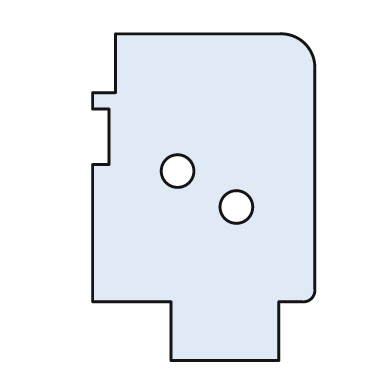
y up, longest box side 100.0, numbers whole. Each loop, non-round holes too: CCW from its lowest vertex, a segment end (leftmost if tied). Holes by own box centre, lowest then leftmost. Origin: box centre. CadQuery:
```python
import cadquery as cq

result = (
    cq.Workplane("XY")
    .moveTo(-10.0, -50.0)
    .lineTo(23.0, -50.0)
    .lineTo(23.0, -32.0)
    .lineTo(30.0, -32.0)
    .threePointArc((33.0, -31.0), (34.0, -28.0))
    .lineTo(34.0, 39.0)
    .threePointArc((31.0, 47.0), (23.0, 50.0))
    .lineTo(-27.0, 50.0)
    .lineTo(-27.0, 32.0)
    .lineTo(-34.0, 32.0)
    .lineTo(-34.0, 27.0)
    .lineTo(-29.0, 27.0)
    .lineTo(-29.0, 10.0)
    .lineTo(-34.0, 10.0)
    .lineTo(-34.0, -32.0)
    .lineTo(-10.0, -32.0)
    .close()
    .moveTo(10.0, -3.0)
    .circle(5.0)
    .moveTo(-8.0, 8.0)
    .circle(5.0)
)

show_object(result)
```